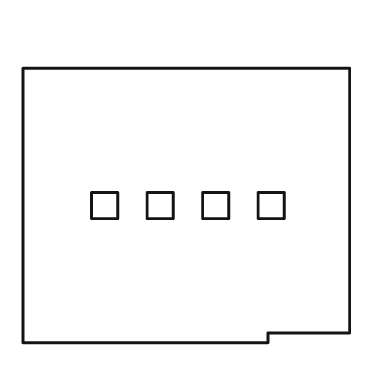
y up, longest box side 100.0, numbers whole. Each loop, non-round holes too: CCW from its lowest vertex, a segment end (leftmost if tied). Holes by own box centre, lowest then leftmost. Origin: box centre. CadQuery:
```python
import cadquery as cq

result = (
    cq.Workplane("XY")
    .moveTo(-50.0, -42.0)
    .lineTo(25.0, -42.0)
    .lineTo(25.0, -39.0)
    .lineTo(50.0, -39.0)
    .lineTo(50.0, 42.0)
    .lineTo(-50.0, 42.0)
    .close()
    .moveTo(-29.0, -4.0)
    .lineTo(-21.0, -4.0)
    .lineTo(-21.0, 4.0)
    .lineTo(-29.0, 4.0)
    .close()
    .moveTo(-12.0, -4.0)
    .lineTo(-4.0, -4.0)
    .lineTo(-4.0, 4.0)
    .lineTo(-12.0, 4.0)
    .close()
    .moveTo(5.0, -4.0)
    .lineTo(13.0, -4.0)
    .lineTo(13.0, 4.0)
    .lineTo(5.0, 4.0)
    .close()
    .moveTo(22.0, -4.0)
    .lineTo(30.0, -4.0)
    .lineTo(30.0, 4.0)
    .lineTo(22.0, 4.0)
    .close()
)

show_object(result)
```